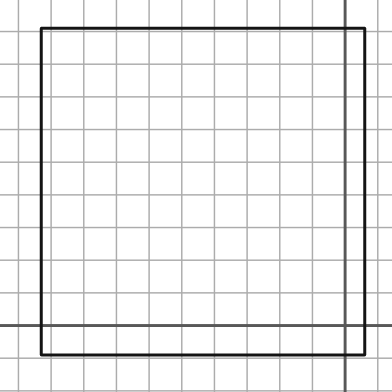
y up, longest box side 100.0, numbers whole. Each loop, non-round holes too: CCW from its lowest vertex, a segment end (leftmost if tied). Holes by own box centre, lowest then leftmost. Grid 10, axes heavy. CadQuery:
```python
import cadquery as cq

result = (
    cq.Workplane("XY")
    .moveTo(-93.0, -9.0)
    .lineTo(6.0, -9.0)
    .lineTo(6.0, 91.0)
    .lineTo(-93.0, 91.0)
    .close()
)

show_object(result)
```